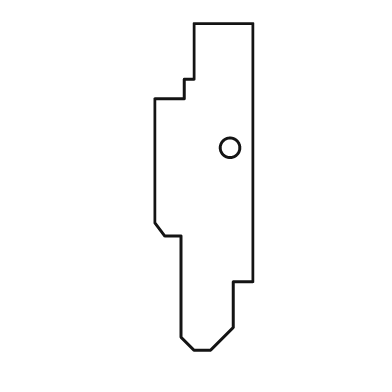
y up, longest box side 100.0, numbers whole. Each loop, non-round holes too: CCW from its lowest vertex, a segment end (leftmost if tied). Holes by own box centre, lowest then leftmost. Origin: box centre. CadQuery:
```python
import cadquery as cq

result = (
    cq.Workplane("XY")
    .moveTo(-3.0, -50.0)
    .lineTo(2.0, -50.0)
    .lineTo(9.0, -43.0)
    .lineTo(9.0, -29.0)
    .lineTo(15.0, -29.0)
    .lineTo(15.0, 50.0)
    .lineTo(-3.0, 50.0)
    .lineTo(-3.0, 33.0)
    .lineTo(-6.0, 33.0)
    .lineTo(-6.0, 27.0)
    .lineTo(-15.0, 27.0)
    .lineTo(-15.0, -11.0)
    .lineTo(-12.0, -15.0)
    .lineTo(-7.0, -15.0)
    .lineTo(-7.0, -46.0)
    .close()
    .moveTo(8.0, 12.0)
    .circle(3.0)
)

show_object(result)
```